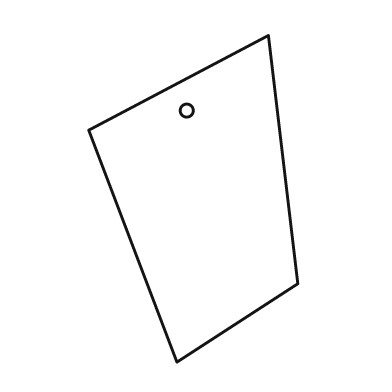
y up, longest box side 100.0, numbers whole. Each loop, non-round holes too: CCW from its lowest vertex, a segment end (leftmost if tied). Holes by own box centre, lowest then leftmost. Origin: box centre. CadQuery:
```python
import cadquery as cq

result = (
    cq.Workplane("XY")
    .moveTo(-5.0, -50.0)
    .lineTo(32.0, -26.0)
    .lineTo(23.0, 50.0)
    .lineTo(-32.0, 21.0)
    .close()
    .moveTo(-2.0, 27.0)
    .circle(2.0)
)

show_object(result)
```